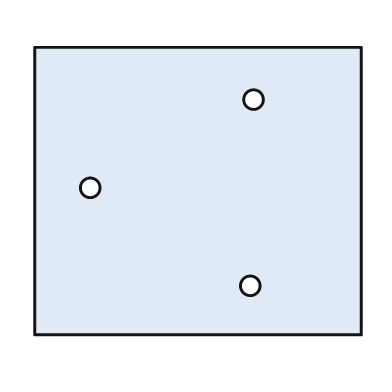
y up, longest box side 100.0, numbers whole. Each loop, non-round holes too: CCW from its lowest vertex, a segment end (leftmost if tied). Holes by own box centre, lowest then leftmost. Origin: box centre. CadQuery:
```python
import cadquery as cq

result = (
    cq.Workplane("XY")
    .moveTo(-50.0, -44.0)
    .lineTo(50.0, -44.0)
    .lineTo(50.0, 44.0)
    .lineTo(-50.0, 44.0)
    .close()
    .moveTo(16.0, -29.0)
    .circle(3.0)
    .moveTo(-33.0, 1.0)
    .circle(3.0)
    .moveTo(17.0, 28.0)
    .circle(3.0)
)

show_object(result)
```